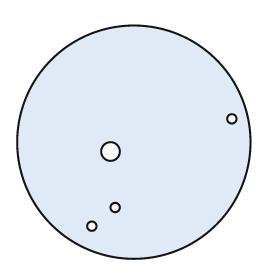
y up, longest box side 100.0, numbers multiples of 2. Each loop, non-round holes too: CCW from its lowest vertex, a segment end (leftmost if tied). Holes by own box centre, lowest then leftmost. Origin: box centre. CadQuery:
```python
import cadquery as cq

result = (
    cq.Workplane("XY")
    .moveTo(0.0, 0.0)
    .circle(50.0)
    .moveTo(-18.0, -36.0)
    .circle(2.0)
    .moveTo(-8.0, -28.0)
    .circle(2.0)
    .moveTo(-10.0, -4.0)
    .circle(4.0)
    .moveTo(42.0, 10.0)
    .circle(2.0)
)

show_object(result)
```